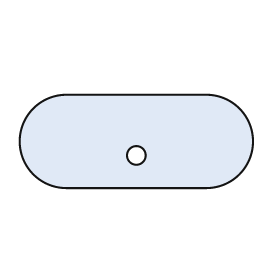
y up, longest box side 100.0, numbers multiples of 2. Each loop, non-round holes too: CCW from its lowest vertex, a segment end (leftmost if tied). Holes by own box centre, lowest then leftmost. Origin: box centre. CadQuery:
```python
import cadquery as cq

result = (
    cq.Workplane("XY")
    .moveTo(-30.0, -20.0)
    .lineTo(30.0, -20.0)
    .threePointArc((50.0, 0.0), (30.0, 20.0))
    .lineTo(-30.0, 20.0)
    .threePointArc((-50.0, 0.0), (-30.0, -20.0))
    .close()
    .moveTo(0.0, -6.0)
    .circle(4.0)
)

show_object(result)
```